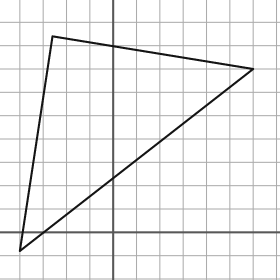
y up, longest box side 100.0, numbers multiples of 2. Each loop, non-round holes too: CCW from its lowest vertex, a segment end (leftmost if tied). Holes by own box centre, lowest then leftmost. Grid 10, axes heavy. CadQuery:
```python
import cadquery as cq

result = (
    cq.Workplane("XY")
    .moveTo(-40.0, -8.0)
    .lineTo(60.0, 70.0)
    .lineTo(-26.0, 84.0)
    .close()
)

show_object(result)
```